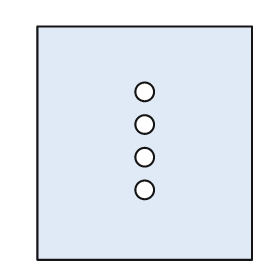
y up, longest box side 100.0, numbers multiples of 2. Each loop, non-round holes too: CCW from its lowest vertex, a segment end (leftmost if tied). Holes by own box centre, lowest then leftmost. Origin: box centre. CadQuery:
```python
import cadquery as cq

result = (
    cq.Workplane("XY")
    .moveTo(-46.0, -50.0)
    .lineTo(46.0, -50.0)
    .lineTo(46.0, 50.0)
    .lineTo(-46.0, 50.0)
    .close()
    .moveTo(0.0, -20.0)
    .circle(4.0)
    .moveTo(0.0, -6.0)
    .circle(4.0)
    .moveTo(0.0, 8.0)
    .circle(4.0)
    .moveTo(0.0, 22.0)
    .circle(4.0)
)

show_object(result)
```